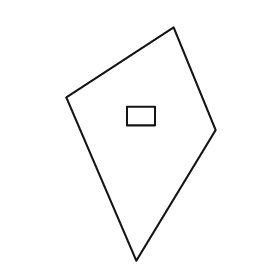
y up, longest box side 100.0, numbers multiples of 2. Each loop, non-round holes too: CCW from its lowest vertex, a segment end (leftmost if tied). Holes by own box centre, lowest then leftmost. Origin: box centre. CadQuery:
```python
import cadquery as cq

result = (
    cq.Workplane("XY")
    .moveTo(-2.0, -50.0)
    .lineTo(32.0, 6.0)
    .lineTo(14.0, 50.0)
    .lineTo(-32.0, 20.0)
    .close()
    .moveTo(-6.0, 8.0)
    .lineTo(6.0, 8.0)
    .lineTo(6.0, 16.0)
    .lineTo(-6.0, 16.0)
    .close()
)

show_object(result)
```